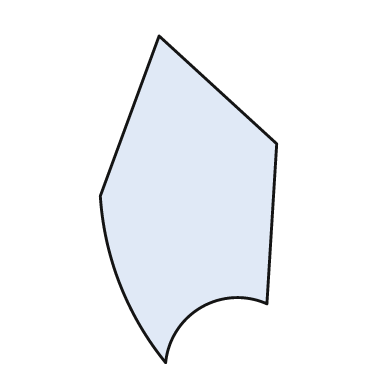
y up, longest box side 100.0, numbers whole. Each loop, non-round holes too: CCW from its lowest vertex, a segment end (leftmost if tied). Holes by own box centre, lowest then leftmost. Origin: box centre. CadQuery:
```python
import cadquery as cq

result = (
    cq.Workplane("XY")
    .moveTo(-7.0, -50.0)
    .threePointArc((4.0, -33.0), (24.0, -32.0))
    .lineTo(27.0, 17.0)
    .lineTo(-9.0, 50.0)
    .lineTo(-27.0, 1.0)
    .threePointArc((-21.0, -26.0), (-7.0, -50.0))
    .close()
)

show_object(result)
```